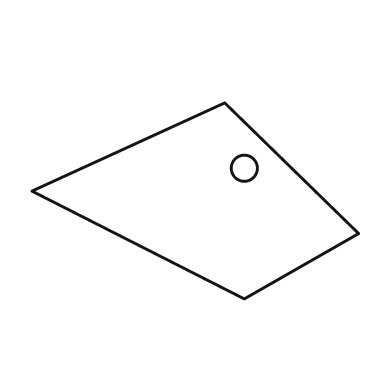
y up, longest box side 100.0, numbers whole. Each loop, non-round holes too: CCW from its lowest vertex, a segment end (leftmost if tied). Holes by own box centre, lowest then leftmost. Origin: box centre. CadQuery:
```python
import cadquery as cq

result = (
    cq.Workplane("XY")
    .moveTo(15.0, -30.0)
    .lineTo(50.0, -10.0)
    .lineTo(9.0, 30.0)
    .lineTo(-50.0, 3.0)
    .close()
    .moveTo(15.0, 10.0)
    .circle(4.0)
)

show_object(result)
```